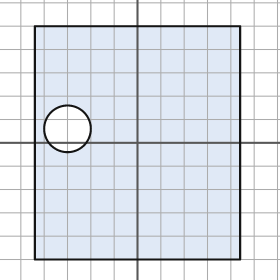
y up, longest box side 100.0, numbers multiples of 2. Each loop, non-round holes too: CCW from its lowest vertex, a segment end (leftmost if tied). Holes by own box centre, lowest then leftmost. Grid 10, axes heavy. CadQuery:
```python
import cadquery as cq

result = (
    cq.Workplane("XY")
    .moveTo(-44.0, -50.0)
    .lineTo(44.0, -50.0)
    .lineTo(44.0, 50.0)
    .lineTo(-44.0, 50.0)
    .close()
    .moveTo(-30.0, 6.0)
    .circle(10.0)
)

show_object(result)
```